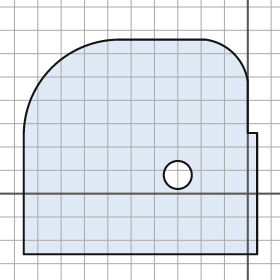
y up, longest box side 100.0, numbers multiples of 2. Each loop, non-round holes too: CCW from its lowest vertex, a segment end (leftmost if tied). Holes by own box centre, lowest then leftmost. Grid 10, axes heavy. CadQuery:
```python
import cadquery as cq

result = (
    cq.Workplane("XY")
    .moveTo(-96.0, -26.0)
    .lineTo(4.0, -26.0)
    .lineTo(4.0, 26.0)
    .lineTo(0.0, 26.0)
    .lineTo(0.0, 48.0)
    .threePointArc((-6.0, 60.0), (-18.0, 66.0))
    .lineTo(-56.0, 66.0)
    .threePointArc((-84.0, 54.0), (-96.0, 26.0))
    .close()
    .moveTo(-30.0, 8.0)
    .circle(6.0)
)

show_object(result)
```